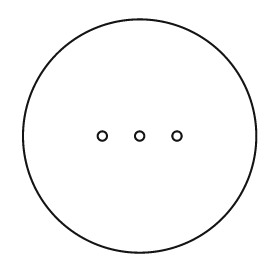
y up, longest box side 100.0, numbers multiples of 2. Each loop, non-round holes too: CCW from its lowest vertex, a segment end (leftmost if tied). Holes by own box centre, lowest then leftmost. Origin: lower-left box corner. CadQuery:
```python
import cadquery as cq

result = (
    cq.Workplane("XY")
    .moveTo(50.0, 50.0)
    .circle(50.0)
    .moveTo(34.0, 50.0)
    .circle(2.0)
    .moveTo(50.0, 50.0)
    .circle(2.0)
    .moveTo(66.0, 50.0)
    .circle(2.0)
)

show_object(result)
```